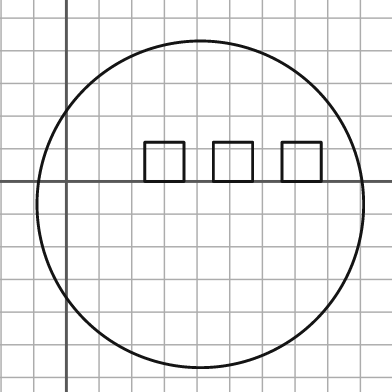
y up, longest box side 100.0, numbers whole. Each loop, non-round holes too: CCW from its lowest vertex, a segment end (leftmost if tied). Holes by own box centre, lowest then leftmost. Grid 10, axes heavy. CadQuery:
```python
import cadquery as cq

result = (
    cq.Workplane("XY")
    .moveTo(41.0, -7.0)
    .circle(50.0)
    .moveTo(24.0, 0.0)
    .lineTo(36.0, 0.0)
    .lineTo(36.0, 12.0)
    .lineTo(24.0, 12.0)
    .close()
    .moveTo(45.0, 0.0)
    .lineTo(57.0, 0.0)
    .lineTo(57.0, 12.0)
    .lineTo(45.0, 12.0)
    .close()
    .moveTo(66.0, 0.0)
    .lineTo(78.0, 0.0)
    .lineTo(78.0, 12.0)
    .lineTo(66.0, 12.0)
    .close()
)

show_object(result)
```